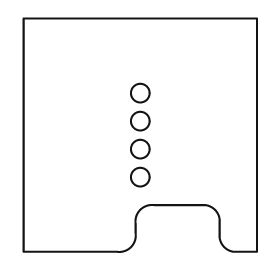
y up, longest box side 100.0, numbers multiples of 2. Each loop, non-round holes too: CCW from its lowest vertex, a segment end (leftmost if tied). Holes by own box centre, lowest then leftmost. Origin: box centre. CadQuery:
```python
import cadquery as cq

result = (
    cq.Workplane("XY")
    .moveTo(-50.0, -50.0)
    .lineTo(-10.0, -50.0)
    .threePointArc((-4.0, -48.0), (-2.0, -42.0))
    .lineTo(-2.0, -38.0)
    .threePointArc((0.0, -32.0), (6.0, -30.0))
    .lineTo(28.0, -30.0)
    .threePointArc((32.0, -32.0), (34.0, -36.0))
    .lineTo(34.0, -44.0)
    .threePointArc((36.0, -48.0), (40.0, -50.0))
    .lineTo(50.0, -50.0)
    .lineTo(50.0, 50.0)
    .lineTo(-50.0, 50.0)
    .close()
    .moveTo(0.0, -18.0)
    .circle(4.0)
    .moveTo(0.0, -6.0)
    .circle(4.0)
    .moveTo(0.0, 6.0)
    .circle(4.0)
    .moveTo(0.0, 18.0)
    .circle(4.0)
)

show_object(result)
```